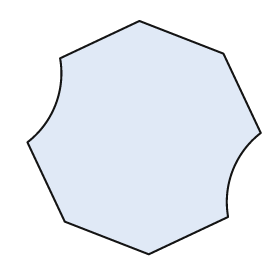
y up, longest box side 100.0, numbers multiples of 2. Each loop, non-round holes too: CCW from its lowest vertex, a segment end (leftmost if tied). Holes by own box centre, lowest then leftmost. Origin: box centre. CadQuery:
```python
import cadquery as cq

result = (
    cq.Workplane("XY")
    .moveTo(2.0, -50.0)
    .lineTo(36.0, -34.0)
    .threePointArc((38.0, -14.0), (50.0, 2.0))
    .lineTo(34.0, 36.0)
    .lineTo(-2.0, 50.0)
    .lineTo(-36.0, 34.0)
    .threePointArc((-38.0, 14.0), (-50.0, -2.0))
    .lineTo(-34.0, -36.0)
    .close()
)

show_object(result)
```